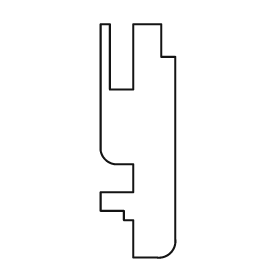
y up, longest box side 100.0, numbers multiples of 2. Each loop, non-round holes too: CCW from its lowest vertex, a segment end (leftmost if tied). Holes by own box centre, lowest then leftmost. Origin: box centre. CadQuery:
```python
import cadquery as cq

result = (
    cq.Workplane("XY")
    .moveTo(-2.0, -50.0)
    .lineTo(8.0, -50.0)
    .threePointArc((14.0, -48.0), (16.0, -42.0))
    .lineTo(16.0, 36.0)
    .lineTo(10.0, 36.0)
    .lineTo(10.0, 50.0)
    .lineTo(-2.0, 50.0)
    .lineTo(-2.0, 22.0)
    .lineTo(-12.0, 22.0)
    .lineTo(-12.0, 50.0)
    .lineTo(-16.0, 50.0)
    .lineTo(-16.0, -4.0)
    .threePointArc((-14.0, -8.0), (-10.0, -10.0))
    .lineTo(-2.0, -10.0)
    .lineTo(-2.0, -22.0)
    .lineTo(-16.0, -22.0)
    .lineTo(-16.0, -30.0)
    .lineTo(-6.0, -30.0)
    .lineTo(-6.0, -34.0)
    .lineTo(-2.0, -34.0)
    .close()
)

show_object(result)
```